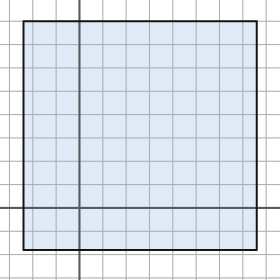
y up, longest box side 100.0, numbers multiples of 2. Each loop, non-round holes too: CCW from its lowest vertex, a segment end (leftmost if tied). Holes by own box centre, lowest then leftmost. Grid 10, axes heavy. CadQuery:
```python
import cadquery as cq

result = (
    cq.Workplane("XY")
    .moveTo(-24.0, -18.0)
    .lineTo(76.0, -18.0)
    .lineTo(76.0, 80.0)
    .lineTo(-24.0, 80.0)
    .close()
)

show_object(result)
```